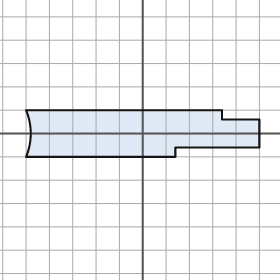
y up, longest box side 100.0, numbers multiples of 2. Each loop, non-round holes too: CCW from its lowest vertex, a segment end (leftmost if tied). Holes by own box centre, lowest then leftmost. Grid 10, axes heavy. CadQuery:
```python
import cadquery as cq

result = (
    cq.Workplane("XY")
    .moveTo(-50.0, -10.0)
    .lineTo(14.0, -10.0)
    .lineTo(14.0, -6.0)
    .lineTo(50.0, -6.0)
    .lineTo(50.0, 6.0)
    .lineTo(34.0, 6.0)
    .lineTo(34.0, 10.0)
    .lineTo(-50.0, 10.0)
    .threePointArc((-48.0, 0.0), (-50.0, -10.0))
    .close()
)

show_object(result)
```